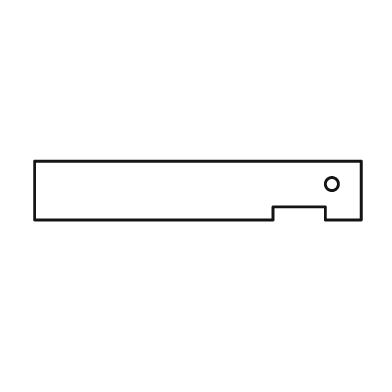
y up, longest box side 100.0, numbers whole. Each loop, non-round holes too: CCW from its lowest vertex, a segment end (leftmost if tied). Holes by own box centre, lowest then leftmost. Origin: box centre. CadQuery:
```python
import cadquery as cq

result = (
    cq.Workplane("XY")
    .moveTo(-50.0, -9.0)
    .lineTo(23.0, -9.0)
    .lineTo(23.0, -5.0)
    .lineTo(39.0, -5.0)
    .lineTo(39.0, -9.0)
    .lineTo(50.0, -9.0)
    .lineTo(50.0, 9.0)
    .lineTo(-50.0, 9.0)
    .close()
    .moveTo(41.0, 2.0)
    .circle(2.0)
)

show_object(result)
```